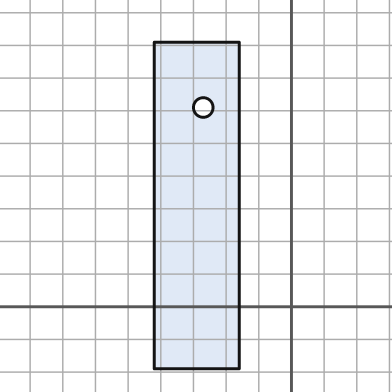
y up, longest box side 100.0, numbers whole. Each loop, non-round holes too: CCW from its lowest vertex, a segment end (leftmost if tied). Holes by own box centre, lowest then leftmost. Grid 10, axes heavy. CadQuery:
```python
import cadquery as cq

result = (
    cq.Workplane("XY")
    .moveTo(-42.0, -19.0)
    .lineTo(-16.0, -19.0)
    .lineTo(-16.0, 81.0)
    .lineTo(-42.0, 81.0)
    .close()
    .moveTo(-27.0, 61.0)
    .circle(3.0)
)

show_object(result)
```